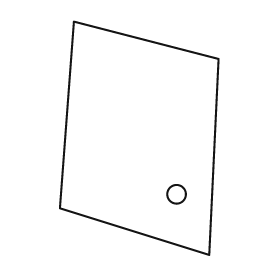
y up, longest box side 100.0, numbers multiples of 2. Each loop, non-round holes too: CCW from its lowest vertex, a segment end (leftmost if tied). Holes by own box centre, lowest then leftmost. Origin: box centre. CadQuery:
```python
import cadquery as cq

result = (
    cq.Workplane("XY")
    .moveTo(30.0, -50.0)
    .lineTo(34.0, 34.0)
    .lineTo(-28.0, 50.0)
    .lineTo(-34.0, -30.0)
    .close()
    .moveTo(16.0, -24.0)
    .circle(4.0)
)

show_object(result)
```